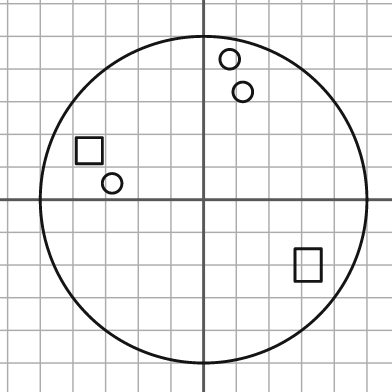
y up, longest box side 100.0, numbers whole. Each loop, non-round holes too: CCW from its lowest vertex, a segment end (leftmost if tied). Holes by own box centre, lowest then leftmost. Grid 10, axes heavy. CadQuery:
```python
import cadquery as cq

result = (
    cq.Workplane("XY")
    .moveTo(0.0, 0.0)
    .circle(50.0)
    .moveTo(28.0, -25.0)
    .lineTo(36.0, -25.0)
    .lineTo(36.0, -15.0)
    .lineTo(28.0, -15.0)
    .close()
    .moveTo(-28.0, 5.0)
    .circle(3.0)
    .moveTo(-39.0, 11.0)
    .lineTo(-31.0, 11.0)
    .lineTo(-31.0, 19.0)
    .lineTo(-39.0, 19.0)
    .close()
    .moveTo(12.0, 33.0)
    .circle(3.0)
    .moveTo(8.0, 43.0)
    .circle(3.0)
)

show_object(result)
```